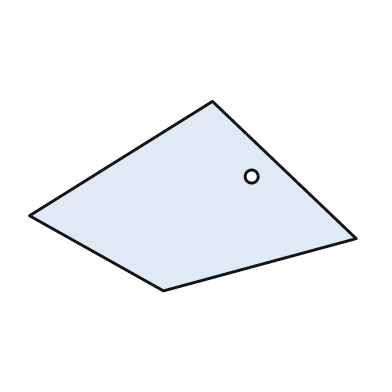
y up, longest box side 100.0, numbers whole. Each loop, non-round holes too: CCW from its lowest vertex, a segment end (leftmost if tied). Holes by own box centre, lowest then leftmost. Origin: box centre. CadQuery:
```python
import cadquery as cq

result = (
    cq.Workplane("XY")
    .moveTo(-9.0, -29.0)
    .lineTo(50.0, -13.0)
    .lineTo(6.0, 29.0)
    .lineTo(-50.0, -6.0)
    .close()
    .moveTo(18.0, 6.0)
    .circle(2.0)
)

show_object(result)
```